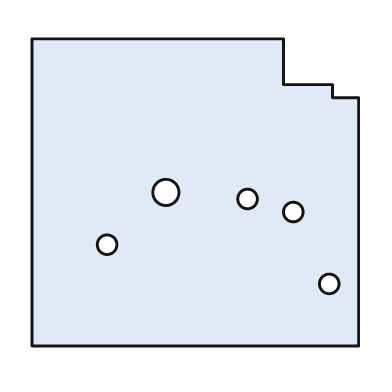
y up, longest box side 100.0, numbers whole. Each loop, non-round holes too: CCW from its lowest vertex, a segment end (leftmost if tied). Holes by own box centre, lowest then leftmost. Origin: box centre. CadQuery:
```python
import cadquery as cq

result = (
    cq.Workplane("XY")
    .moveTo(-50.0, -47.0)
    .lineTo(50.0, -47.0)
    .lineTo(50.0, 29.0)
    .lineTo(42.0, 29.0)
    .lineTo(42.0, 33.0)
    .lineTo(27.0, 33.0)
    .lineTo(27.0, 47.0)
    .lineTo(-50.0, 47.0)
    .close()
    .moveTo(41.0, -28.0)
    .circle(3.0)
    .moveTo(-27.0, -16.0)
    .circle(3.0)
    .moveTo(30.0, -6.0)
    .circle(3.0)
    .moveTo(16.0, -2.0)
    .circle(3.0)
    .moveTo(-9.0, 0.0)
    .circle(4.0)
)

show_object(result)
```